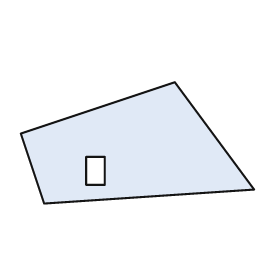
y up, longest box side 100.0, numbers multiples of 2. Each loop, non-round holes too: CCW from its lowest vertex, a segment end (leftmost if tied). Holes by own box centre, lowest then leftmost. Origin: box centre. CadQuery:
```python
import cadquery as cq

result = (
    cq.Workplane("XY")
    .moveTo(-40.0, -26.0)
    .lineTo(50.0, -20.0)
    .lineTo(16.0, 26.0)
    .lineTo(-50.0, 4.0)
    .close()
    .moveTo(-22.0, -18.0)
    .lineTo(-14.0, -18.0)
    .lineTo(-14.0, -6.0)
    .lineTo(-22.0, -6.0)
    .close()
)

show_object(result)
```